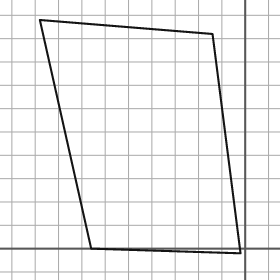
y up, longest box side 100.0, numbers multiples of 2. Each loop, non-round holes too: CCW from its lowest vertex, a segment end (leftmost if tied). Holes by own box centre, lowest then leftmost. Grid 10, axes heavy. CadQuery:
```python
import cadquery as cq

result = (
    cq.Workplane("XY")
    .moveTo(-2.0, -2.0)
    .lineTo(-14.0, 92.0)
    .lineTo(-88.0, 98.0)
    .lineTo(-66.0, 0.0)
    .close()
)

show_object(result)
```